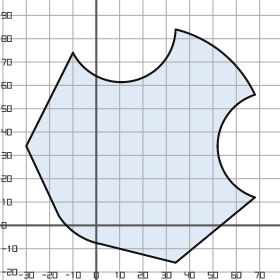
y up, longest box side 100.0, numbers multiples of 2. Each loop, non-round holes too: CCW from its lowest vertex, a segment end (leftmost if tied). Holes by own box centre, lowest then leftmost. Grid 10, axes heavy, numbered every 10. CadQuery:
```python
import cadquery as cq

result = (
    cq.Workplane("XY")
    .moveTo(34.0, -16.0)
    .lineTo(68.0, 12.0)
    .threePointArc((52.0, 34.0), (68.0, 56.0))
    .threePointArc((54.0, 74.0), (34.0, 84.0))
    .threePointArc((16.0, 62.0), (-10.0, 74.0))
    .lineTo(-30.0, 34.0)
    .lineTo(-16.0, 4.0)
    .threePointArc((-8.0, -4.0), (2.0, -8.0))
    .close()
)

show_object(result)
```